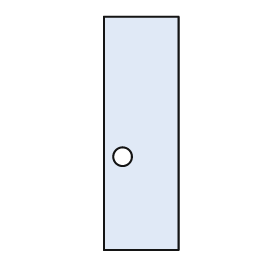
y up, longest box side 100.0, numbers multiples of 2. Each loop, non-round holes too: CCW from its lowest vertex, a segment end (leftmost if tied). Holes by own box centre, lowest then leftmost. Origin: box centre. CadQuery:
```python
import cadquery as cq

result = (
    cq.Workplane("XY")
    .moveTo(-16.0, -50.0)
    .lineTo(16.0, -50.0)
    .lineTo(16.0, 50.0)
    .lineTo(-16.0, 50.0)
    .close()
    .moveTo(-8.0, -10.0)
    .circle(4.0)
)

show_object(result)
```